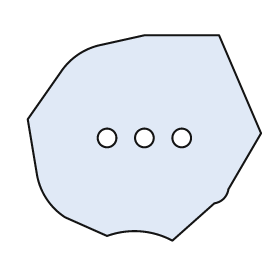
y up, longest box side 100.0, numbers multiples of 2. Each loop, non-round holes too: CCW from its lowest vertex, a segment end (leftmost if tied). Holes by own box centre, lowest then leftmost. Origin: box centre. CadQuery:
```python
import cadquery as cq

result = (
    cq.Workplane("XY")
    .moveTo(12.0, -44.0)
    .lineTo(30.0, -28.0)
    .threePointArc((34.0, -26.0), (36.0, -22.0))
    .lineTo(50.0, 2.0)
    .lineTo(32.0, 44.0)
    .lineTo(0.0, 44.0)
    .lineTo(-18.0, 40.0)
    .threePointArc((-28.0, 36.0), (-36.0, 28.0))
    .lineTo(-50.0, 8.0)
    .lineTo(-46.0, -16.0)
    .threePointArc((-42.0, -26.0), (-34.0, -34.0))
    .lineTo(-16.0, -42.0)
    .threePointArc((-2.0, -40.0), (12.0, -44.0))
    .close()
    .moveTo(-16.0, 0.0)
    .circle(4.0)
    .moveTo(0.0, 0.0)
    .circle(4.0)
    .moveTo(16.0, 0.0)
    .circle(4.0)
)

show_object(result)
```